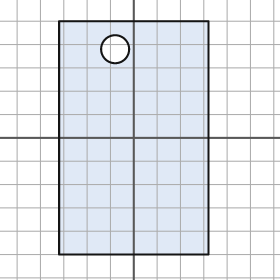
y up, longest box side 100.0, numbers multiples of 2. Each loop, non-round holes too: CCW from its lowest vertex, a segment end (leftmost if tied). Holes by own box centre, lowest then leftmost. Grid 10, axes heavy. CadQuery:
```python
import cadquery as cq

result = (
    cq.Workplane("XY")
    .moveTo(-32.0, -50.0)
    .lineTo(32.0, -50.0)
    .lineTo(32.0, 50.0)
    .lineTo(-32.0, 50.0)
    .close()
    .moveTo(-8.0, 38.0)
    .circle(6.0)
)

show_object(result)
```